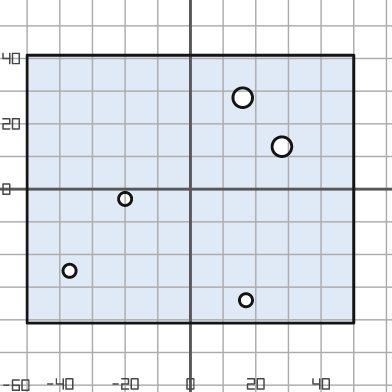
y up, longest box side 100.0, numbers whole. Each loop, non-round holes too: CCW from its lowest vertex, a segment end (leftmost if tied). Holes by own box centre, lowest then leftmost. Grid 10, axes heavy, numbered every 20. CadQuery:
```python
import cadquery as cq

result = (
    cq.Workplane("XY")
    .moveTo(-50.0, -41.0)
    .lineTo(50.0, -41.0)
    .lineTo(50.0, 41.0)
    .lineTo(-50.0, 41.0)
    .close()
    .moveTo(17.0, -34.0)
    .circle(2.0)
    .moveTo(-37.0, -25.0)
    .circle(2.0)
    .moveTo(-20.0, -3.0)
    .circle(2.0)
    .moveTo(28.0, 13.0)
    .circle(3.0)
    .moveTo(16.0, 28.0)
    .circle(3.0)
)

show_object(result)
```